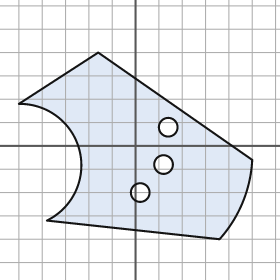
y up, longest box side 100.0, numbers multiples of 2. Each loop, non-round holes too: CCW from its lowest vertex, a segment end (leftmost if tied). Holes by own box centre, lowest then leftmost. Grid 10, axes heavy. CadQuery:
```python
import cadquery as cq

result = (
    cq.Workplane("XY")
    .moveTo(36.0, -40.0)
    .threePointArc((46.0, -24.0), (50.0, -6.0))
    .lineTo(-16.0, 40.0)
    .lineTo(-50.0, 18.0)
    .threePointArc((-24.0, -2.0), (-38.0, -32.0))
    .close()
    .moveTo(2.0, -20.0)
    .circle(4.0)
    .moveTo(12.0, -8.0)
    .circle(4.0)
    .moveTo(14.0, 8.0)
    .circle(4.0)
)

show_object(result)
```